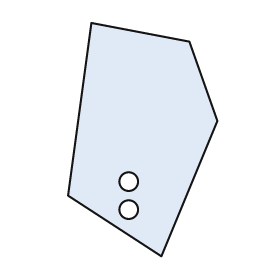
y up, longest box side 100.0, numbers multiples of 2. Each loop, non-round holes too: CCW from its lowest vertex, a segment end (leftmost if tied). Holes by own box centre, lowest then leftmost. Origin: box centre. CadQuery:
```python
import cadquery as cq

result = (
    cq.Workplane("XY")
    .moveTo(8.0, -50.0)
    .lineTo(32.0, 8.0)
    .lineTo(20.0, 42.0)
    .lineTo(-22.0, 50.0)
    .lineTo(-32.0, -24.0)
    .close()
    .moveTo(-6.0, -30.0)
    .circle(4.0)
    .moveTo(-6.0, -18.0)
    .circle(4.0)
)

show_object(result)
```